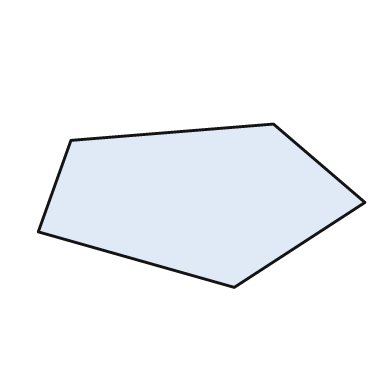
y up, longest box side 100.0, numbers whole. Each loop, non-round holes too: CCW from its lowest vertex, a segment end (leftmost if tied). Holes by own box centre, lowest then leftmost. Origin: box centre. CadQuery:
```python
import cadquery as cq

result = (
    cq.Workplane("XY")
    .moveTo(10.0, -25.0)
    .lineTo(50.0, 1.0)
    .lineTo(22.0, 25.0)
    .lineTo(-40.0, 20.0)
    .lineTo(-50.0, -8.0)
    .close()
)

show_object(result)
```